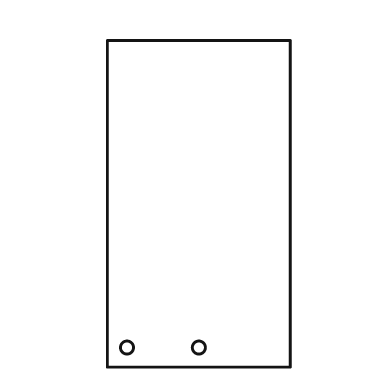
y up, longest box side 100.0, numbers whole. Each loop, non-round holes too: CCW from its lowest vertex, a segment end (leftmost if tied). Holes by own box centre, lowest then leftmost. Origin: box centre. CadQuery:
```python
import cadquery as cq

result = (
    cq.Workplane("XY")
    .moveTo(-28.0, -50.0)
    .lineTo(28.0, -50.0)
    .lineTo(28.0, 50.0)
    .lineTo(-28.0, 50.0)
    .close()
    .moveTo(-22.0, -44.0)
    .circle(2.0)
    .moveTo(0.0, -44.0)
    .circle(2.0)
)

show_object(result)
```